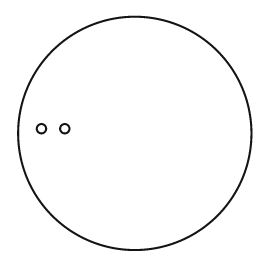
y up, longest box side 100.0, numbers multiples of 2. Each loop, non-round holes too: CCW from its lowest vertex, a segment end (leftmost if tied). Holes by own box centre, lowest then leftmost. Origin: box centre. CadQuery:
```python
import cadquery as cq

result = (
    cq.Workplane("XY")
    .moveTo(0.0, 0.0)
    .circle(50.0)
    .moveTo(-40.0, 2.0)
    .circle(2.0)
    .moveTo(-30.0, 2.0)
    .circle(2.0)
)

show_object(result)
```